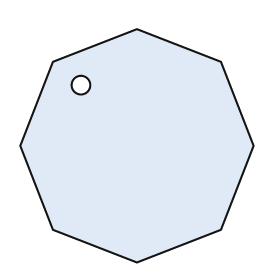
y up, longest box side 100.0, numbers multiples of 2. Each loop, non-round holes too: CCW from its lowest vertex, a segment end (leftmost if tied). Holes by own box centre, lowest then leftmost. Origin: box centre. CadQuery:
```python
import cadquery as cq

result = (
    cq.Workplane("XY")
    .moveTo(0.0, -50.0)
    .lineTo(36.0, -36.0)
    .lineTo(50.0, 0.0)
    .lineTo(36.0, 36.0)
    .lineTo(0.0, 50.0)
    .lineTo(-36.0, 36.0)
    .lineTo(-50.0, 0.0)
    .lineTo(-36.0, -36.0)
    .close()
    .moveTo(-24.0, 26.0)
    .circle(4.0)
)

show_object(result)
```